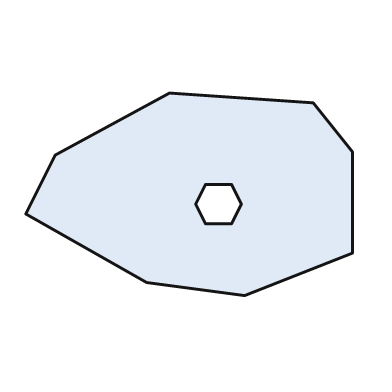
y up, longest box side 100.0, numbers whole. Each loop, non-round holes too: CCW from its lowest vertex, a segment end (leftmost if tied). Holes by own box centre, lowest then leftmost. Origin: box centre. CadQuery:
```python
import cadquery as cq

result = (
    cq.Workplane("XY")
    .moveTo(17.0, -31.0)
    .lineTo(50.0, -18.0)
    .lineTo(50.0, 13.0)
    .lineTo(38.0, 28.0)
    .lineTo(-6.0, 31.0)
    .lineTo(-41.0, 12.0)
    .lineTo(-50.0, -6.0)
    .lineTo(-13.0, -27.0)
    .close()
    .moveTo(5.0, -9.0)
    .lineTo(13.0, -9.0)
    .lineTo(16.0, -3.0)
    .lineTo(13.0, 3.0)
    .lineTo(5.0, 3.0)
    .lineTo(2.0, -3.0)
    .close()
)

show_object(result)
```